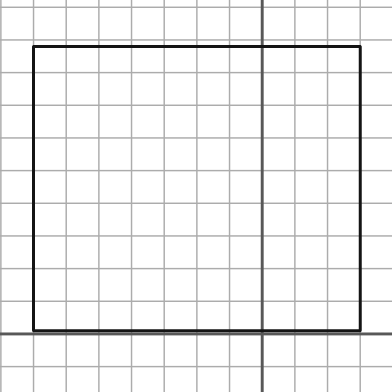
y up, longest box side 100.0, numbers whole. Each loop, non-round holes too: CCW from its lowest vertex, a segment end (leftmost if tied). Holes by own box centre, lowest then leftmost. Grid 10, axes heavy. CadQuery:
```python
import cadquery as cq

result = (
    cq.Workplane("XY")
    .moveTo(-70.0, 1.0)
    .lineTo(30.0, 1.0)
    .lineTo(30.0, 88.0)
    .lineTo(-70.0, 88.0)
    .close()
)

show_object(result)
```